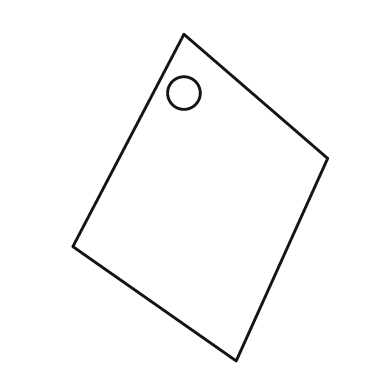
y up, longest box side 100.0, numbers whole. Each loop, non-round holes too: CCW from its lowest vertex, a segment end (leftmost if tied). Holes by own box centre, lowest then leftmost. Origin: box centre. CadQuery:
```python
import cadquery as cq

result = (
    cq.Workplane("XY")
    .moveTo(11.0, -50.0)
    .lineTo(39.0, 12.0)
    .lineTo(-5.0, 50.0)
    .lineTo(-39.0, -15.0)
    .close()
    .moveTo(-5.0, 32.0)
    .circle(5.0)
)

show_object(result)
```